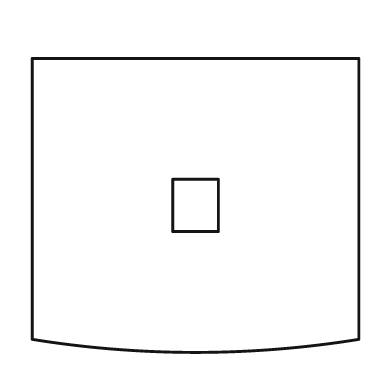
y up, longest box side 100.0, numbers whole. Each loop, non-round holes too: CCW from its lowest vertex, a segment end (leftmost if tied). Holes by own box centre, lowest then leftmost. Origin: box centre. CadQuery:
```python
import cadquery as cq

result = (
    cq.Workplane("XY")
    .moveTo(-50.0, -41.0)
    .threePointArc((0.0, -45.0), (50.0, -41.0))
    .lineTo(50.0, 45.0)
    .lineTo(-50.0, 45.0)
    .close()
    .moveTo(-7.0, -8.0)
    .lineTo(7.0, -8.0)
    .lineTo(7.0, 8.0)
    .lineTo(-7.0, 8.0)
    .close()
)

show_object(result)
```